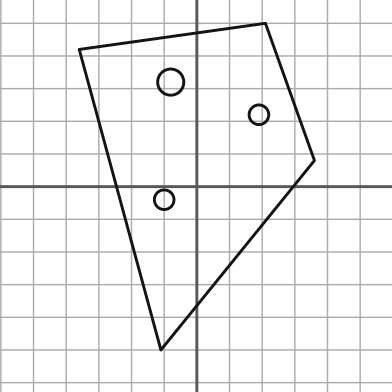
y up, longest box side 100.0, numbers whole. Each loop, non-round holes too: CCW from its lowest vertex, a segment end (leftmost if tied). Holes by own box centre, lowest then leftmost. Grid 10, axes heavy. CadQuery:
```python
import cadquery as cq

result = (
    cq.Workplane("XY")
    .moveTo(-11.0, -50.0)
    .lineTo(36.0, 8.0)
    .lineTo(21.0, 50.0)
    .lineTo(-36.0, 42.0)
    .close()
    .moveTo(-10.0, -4.0)
    .circle(3.0)
    .moveTo(19.0, 22.0)
    .circle(3.0)
    .moveTo(-8.0, 32.0)
    .circle(4.0)
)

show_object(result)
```